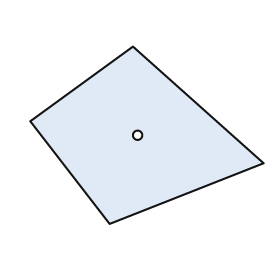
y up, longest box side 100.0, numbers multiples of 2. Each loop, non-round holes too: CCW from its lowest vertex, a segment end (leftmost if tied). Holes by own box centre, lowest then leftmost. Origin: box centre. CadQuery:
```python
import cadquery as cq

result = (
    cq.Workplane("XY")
    .moveTo(-16.0, -38.0)
    .lineTo(50.0, -12.0)
    .lineTo(-6.0, 38.0)
    .lineTo(-50.0, 6.0)
    .close()
    .moveTo(-4.0, 0.0)
    .circle(2.0)
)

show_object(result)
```